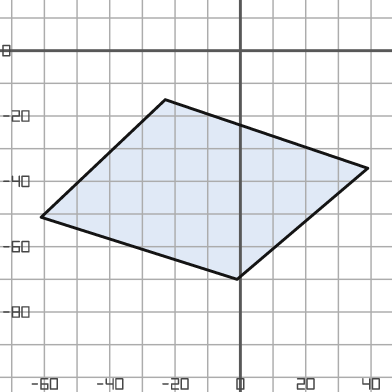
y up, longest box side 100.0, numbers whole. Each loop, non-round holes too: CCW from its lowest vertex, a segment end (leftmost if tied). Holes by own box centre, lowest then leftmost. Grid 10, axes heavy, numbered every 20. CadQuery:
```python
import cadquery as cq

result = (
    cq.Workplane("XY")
    .moveTo(-1.0, -70.0)
    .lineTo(39.0, -36.0)
    .lineTo(-23.0, -15.0)
    .lineTo(-61.0, -51.0)
    .close()
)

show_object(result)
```